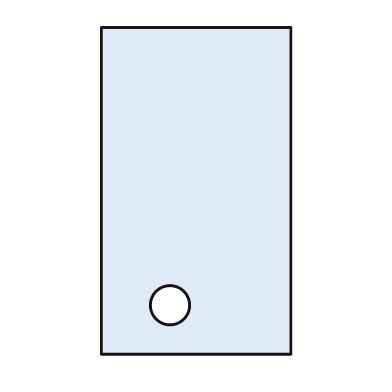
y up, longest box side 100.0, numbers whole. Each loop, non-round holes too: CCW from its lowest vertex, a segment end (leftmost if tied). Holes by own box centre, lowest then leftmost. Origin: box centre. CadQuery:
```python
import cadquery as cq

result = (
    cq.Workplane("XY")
    .moveTo(-29.0, -50.0)
    .lineTo(29.0, -50.0)
    .lineTo(29.0, 50.0)
    .lineTo(-29.0, 50.0)
    .close()
    .moveTo(-8.0, -35.0)
    .circle(6.0)
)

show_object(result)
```